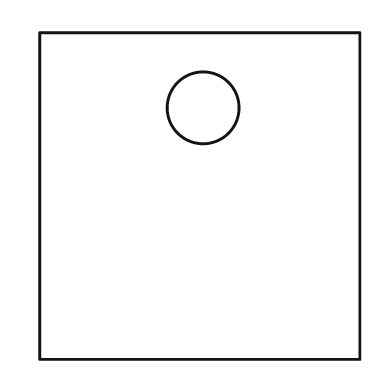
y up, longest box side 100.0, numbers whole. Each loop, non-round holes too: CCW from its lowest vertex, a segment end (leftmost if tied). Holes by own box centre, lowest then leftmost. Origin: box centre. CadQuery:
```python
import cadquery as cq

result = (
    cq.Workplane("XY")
    .moveTo(-49.0, -50.0)
    .lineTo(49.0, -50.0)
    .lineTo(49.0, 50.0)
    .lineTo(-49.0, 50.0)
    .close()
    .moveTo(1.0, 27.0)
    .circle(11.0)
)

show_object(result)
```